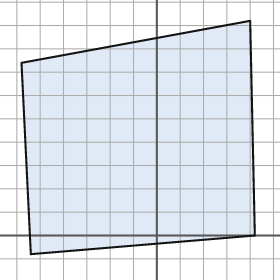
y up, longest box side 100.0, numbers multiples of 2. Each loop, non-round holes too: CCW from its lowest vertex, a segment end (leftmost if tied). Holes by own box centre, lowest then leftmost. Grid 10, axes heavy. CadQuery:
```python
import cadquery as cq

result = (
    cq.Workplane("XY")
    .moveTo(-54.0, -8.0)
    .lineTo(42.0, 0.0)
    .lineTo(40.0, 92.0)
    .lineTo(-58.0, 74.0)
    .close()
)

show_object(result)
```